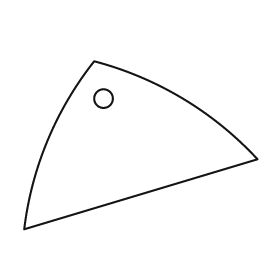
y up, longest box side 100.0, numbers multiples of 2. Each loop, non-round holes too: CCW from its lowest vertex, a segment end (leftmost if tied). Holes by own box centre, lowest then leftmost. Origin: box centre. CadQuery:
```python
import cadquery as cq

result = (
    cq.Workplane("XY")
    .moveTo(-50.0, -36.0)
    .lineTo(50.0, -6.0)
    .threePointArc((18.0, 20.0), (-20.0, 36.0))
    .threePointArc((-40.0, 2.0), (-50.0, -36.0))
    .close()
    .moveTo(-16.0, 20.0)
    .circle(4.0)
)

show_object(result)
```